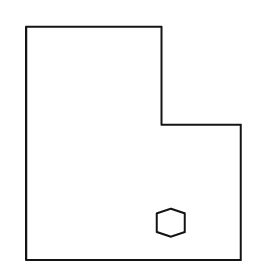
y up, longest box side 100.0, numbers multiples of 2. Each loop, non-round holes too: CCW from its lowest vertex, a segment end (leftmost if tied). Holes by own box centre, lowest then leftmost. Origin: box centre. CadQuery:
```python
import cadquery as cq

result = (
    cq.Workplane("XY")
    .moveTo(-46.0, -50.0)
    .lineTo(46.0, -50.0)
    .lineTo(46.0, 8.0)
    .lineTo(12.0, 8.0)
    .lineTo(12.0, 50.0)
    .lineTo(-46.0, 50.0)
    .close()
    .moveTo(16.0, -40.0)
    .lineTo(22.0, -38.0)
    .lineTo(22.0, -30.0)
    .lineTo(16.0, -28.0)
    .lineTo(10.0, -30.0)
    .lineTo(10.0, -38.0)
    .close()
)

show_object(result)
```